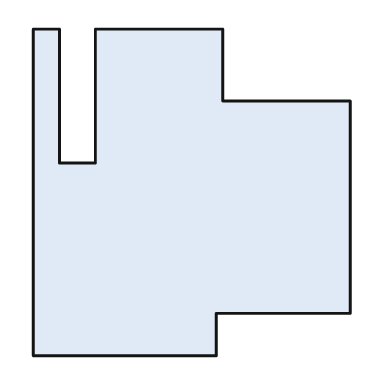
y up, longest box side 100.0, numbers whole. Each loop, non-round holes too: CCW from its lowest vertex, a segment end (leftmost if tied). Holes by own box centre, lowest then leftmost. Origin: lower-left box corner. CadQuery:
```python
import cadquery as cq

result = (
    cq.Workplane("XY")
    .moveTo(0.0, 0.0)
    .lineTo(56.0, 0.0)
    .lineTo(56.0, 13.0)
    .lineTo(97.0, 13.0)
    .lineTo(97.0, 78.0)
    .lineTo(58.0, 78.0)
    .lineTo(58.0, 100.0)
    .lineTo(19.0, 100.0)
    .lineTo(19.0, 59.0)
    .lineTo(8.0, 59.0)
    .lineTo(8.0, 100.0)
    .lineTo(0.0, 100.0)
    .close()
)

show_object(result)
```